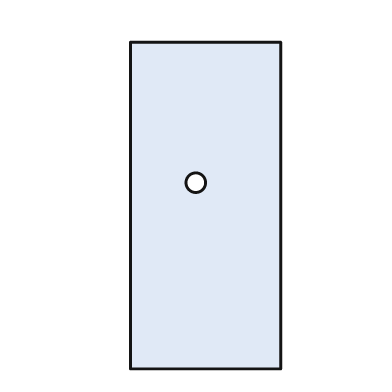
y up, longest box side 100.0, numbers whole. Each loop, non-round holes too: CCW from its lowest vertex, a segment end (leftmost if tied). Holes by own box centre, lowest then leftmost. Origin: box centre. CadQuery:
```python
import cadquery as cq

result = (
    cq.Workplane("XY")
    .moveTo(-23.0, -50.0)
    .lineTo(23.0, -50.0)
    .lineTo(23.0, 50.0)
    .lineTo(-23.0, 50.0)
    .close()
    .moveTo(-3.0, 7.0)
    .circle(3.0)
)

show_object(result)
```